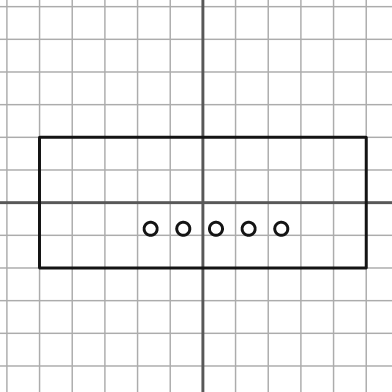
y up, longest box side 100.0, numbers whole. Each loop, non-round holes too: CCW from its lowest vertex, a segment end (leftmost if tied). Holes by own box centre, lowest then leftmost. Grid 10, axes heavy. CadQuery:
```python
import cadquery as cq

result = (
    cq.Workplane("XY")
    .moveTo(-50.0, -20.0)
    .lineTo(50.0, -20.0)
    .lineTo(50.0, 20.0)
    .lineTo(-50.0, 20.0)
    .close()
    .moveTo(-16.0, -8.0)
    .circle(2.0)
    .moveTo(-6.0, -8.0)
    .circle(2.0)
    .moveTo(4.0, -8.0)
    .circle(2.0)
    .moveTo(14.0, -8.0)
    .circle(2.0)
    .moveTo(24.0, -8.0)
    .circle(2.0)
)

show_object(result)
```